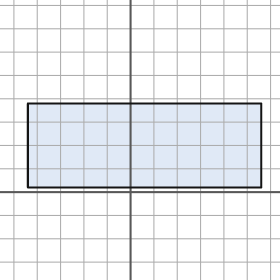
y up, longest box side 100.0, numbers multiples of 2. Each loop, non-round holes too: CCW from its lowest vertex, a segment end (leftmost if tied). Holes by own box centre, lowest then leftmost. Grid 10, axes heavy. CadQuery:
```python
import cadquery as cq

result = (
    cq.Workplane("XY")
    .moveTo(-44.0, 2.0)
    .lineTo(56.0, 2.0)
    .lineTo(56.0, 38.0)
    .lineTo(-44.0, 38.0)
    .close()
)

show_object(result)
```